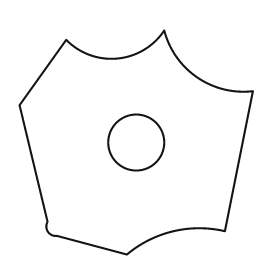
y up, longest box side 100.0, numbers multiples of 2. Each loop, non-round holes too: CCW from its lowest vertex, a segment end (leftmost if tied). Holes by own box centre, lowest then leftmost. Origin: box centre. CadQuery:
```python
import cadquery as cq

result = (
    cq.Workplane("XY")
    .moveTo(-4.0, -48.0)
    .threePointArc((16.0, -38.0), (38.0, -38.0))
    .lineTo(50.0, 22.0)
    .threePointArc((26.0, 28.0), (12.0, 48.0))
    .threePointArc((-8.0, 36.0), (-30.0, 44.0))
    .lineTo(-50.0, 16.0)
    .lineTo(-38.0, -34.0)
    .threePointArc((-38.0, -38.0), (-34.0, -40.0))
    .close()
    .moveTo(0.0, 0.0)
    .circle(12.0)
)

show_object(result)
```